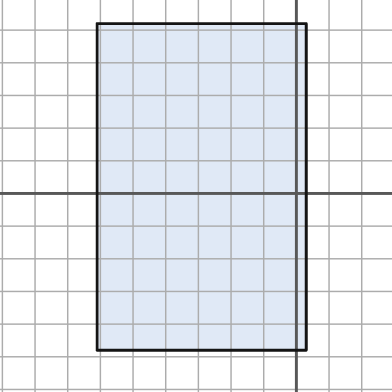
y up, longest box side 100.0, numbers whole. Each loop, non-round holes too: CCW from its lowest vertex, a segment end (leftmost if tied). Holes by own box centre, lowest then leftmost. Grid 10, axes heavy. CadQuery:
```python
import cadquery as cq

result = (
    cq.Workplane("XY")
    .moveTo(-61.0, -48.0)
    .lineTo(3.0, -48.0)
    .lineTo(3.0, 52.0)
    .lineTo(-61.0, 52.0)
    .close()
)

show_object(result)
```